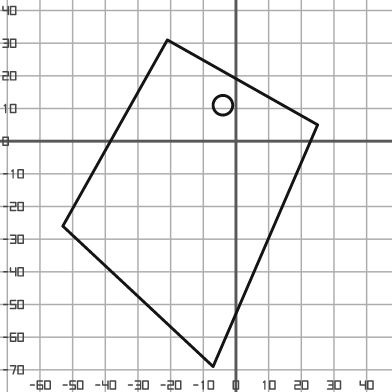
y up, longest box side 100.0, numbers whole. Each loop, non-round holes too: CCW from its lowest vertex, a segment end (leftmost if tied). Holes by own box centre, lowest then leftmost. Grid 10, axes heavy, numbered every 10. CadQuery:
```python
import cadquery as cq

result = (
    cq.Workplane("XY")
    .moveTo(-7.0, -69.0)
    .lineTo(25.0, 5.0)
    .lineTo(-21.0, 31.0)
    .lineTo(-53.0, -26.0)
    .close()
    .moveTo(-4.0, 11.0)
    .circle(3.0)
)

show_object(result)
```